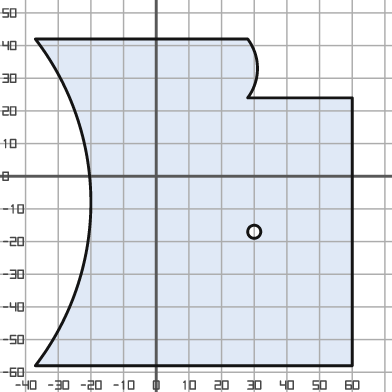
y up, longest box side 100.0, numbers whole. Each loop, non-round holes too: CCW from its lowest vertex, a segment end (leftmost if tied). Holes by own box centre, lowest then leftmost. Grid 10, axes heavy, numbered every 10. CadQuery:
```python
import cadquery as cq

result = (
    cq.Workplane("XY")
    .moveTo(-37.0, -58.0)
    .lineTo(60.0, -58.0)
    .lineTo(60.0, 24.0)
    .lineTo(28.0, 24.0)
    .threePointArc((31.0, 33.0), (28.0, 42.0))
    .lineTo(-37.0, 42.0)
    .threePointArc((-20.0, -8.0), (-37.0, -58.0))
    .close()
    .moveTo(30.0, -17.0)
    .circle(2.0)
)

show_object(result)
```